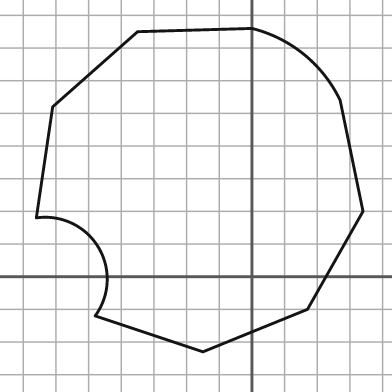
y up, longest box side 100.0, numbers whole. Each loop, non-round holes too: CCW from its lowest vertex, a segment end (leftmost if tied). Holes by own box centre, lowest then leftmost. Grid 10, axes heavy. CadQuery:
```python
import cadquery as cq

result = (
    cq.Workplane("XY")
    .moveTo(-15.0, -23.0)
    .lineTo(17.0, -10.0)
    .lineTo(34.0, 20.0)
    .lineTo(27.0, 54.0)
    .threePointArc((16.0, 68.0), (0.0, 76.0))
    .lineTo(-35.0, 75.0)
    .lineTo(-61.0, 52.0)
    .lineTo(-66.0, 18.0)
    .threePointArc((-47.0, 9.0), (-48.0, -12.0))
    .close()
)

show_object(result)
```